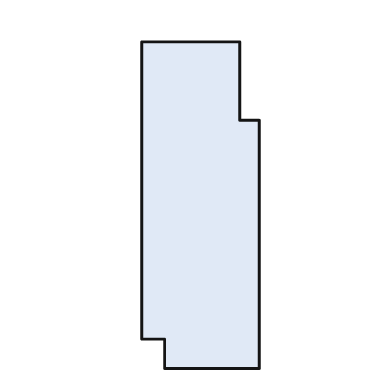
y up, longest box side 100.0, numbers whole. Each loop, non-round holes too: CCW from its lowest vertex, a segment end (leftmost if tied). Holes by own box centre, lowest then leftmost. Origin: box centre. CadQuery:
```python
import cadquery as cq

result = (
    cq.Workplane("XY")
    .moveTo(-11.0, -50.0)
    .lineTo(18.0, -50.0)
    .lineTo(18.0, 26.0)
    .lineTo(12.0, 26.0)
    .lineTo(12.0, 50.0)
    .lineTo(-18.0, 50.0)
    .lineTo(-18.0, -41.0)
    .lineTo(-11.0, -41.0)
    .close()
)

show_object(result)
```